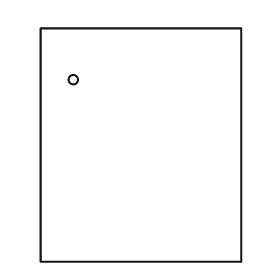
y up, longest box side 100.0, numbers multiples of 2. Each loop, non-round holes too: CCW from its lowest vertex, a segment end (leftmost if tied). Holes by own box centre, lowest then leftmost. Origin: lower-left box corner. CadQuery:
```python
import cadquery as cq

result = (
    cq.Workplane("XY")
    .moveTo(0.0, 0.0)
    .lineTo(86.0, 0.0)
    .lineTo(86.0, 100.0)
    .lineTo(0.0, 100.0)
    .close()
    .moveTo(14.0, 78.0)
    .circle(2.0)
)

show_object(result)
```